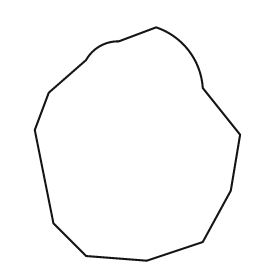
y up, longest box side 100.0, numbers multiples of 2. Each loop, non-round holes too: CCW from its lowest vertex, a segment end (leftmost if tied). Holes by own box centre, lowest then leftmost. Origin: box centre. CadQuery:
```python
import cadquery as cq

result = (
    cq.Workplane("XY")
    .moveTo(4.0, -50.0)
    .lineTo(28.0, -42.0)
    .lineTo(40.0, -20.0)
    .lineTo(44.0, 4.0)
    .lineTo(28.0, 24.0)
    .threePointArc((22.0, 40.0), (8.0, 50.0))
    .lineTo(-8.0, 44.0)
    .threePointArc((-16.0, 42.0), (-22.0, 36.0))
    .lineTo(-38.0, 22.0)
    .lineTo(-44.0, 6.0)
    .lineTo(-36.0, -34.0)
    .lineTo(-22.0, -48.0)
    .close()
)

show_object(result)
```